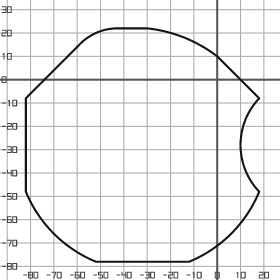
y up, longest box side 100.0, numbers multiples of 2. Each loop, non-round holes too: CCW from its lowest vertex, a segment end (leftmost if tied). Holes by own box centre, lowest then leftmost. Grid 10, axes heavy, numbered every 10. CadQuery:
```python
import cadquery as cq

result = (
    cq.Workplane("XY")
    .moveTo(-52.0, -78.0)
    .lineTo(-12.0, -78.0)
    .threePointArc((6.0, -66.0), (18.0, -48.0))
    .threePointArc((10.0, -28.0), (18.0, -8.0))
    .lineTo(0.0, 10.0)
    .threePointArc((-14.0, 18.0), (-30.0, 22.0))
    .lineTo(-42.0, 22.0)
    .threePointArc((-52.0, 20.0), (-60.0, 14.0))
    .lineTo(-82.0, -8.0)
    .lineTo(-82.0, -48.0)
    .threePointArc((-70.0, -66.0), (-52.0, -78.0))
    .close()
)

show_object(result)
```